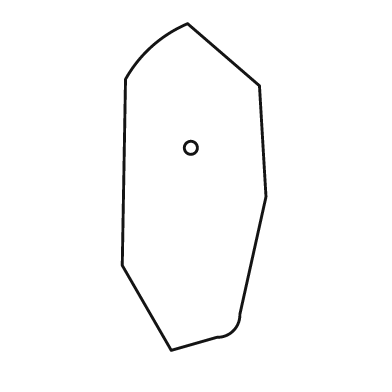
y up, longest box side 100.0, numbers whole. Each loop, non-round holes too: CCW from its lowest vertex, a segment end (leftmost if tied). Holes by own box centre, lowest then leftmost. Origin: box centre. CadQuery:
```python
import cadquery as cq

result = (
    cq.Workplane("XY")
    .moveTo(-7.0, -50.0)
    .lineTo(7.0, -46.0)
    .threePointArc((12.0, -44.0), (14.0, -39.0))
    .lineTo(22.0, -3.0)
    .lineTo(20.0, 31.0)
    .lineTo(-2.0, 50.0)
    .threePointArc((-13.0, 43.0), (-21.0, 33.0))
    .lineTo(-22.0, -24.0)
    .close()
    .moveTo(-1.0, 12.0)
    .circle(2.0)
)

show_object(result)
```